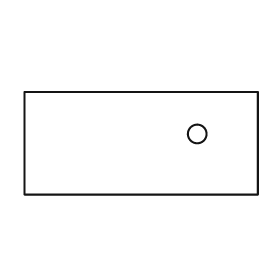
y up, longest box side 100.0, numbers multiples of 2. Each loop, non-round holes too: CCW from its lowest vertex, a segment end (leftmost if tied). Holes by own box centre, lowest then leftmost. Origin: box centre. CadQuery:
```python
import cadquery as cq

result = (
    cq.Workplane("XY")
    .moveTo(-50.0, -22.0)
    .lineTo(50.0, -22.0)
    .lineTo(50.0, 22.0)
    .lineTo(-50.0, 22.0)
    .close()
    .moveTo(24.0, 4.0)
    .circle(4.0)
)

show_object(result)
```